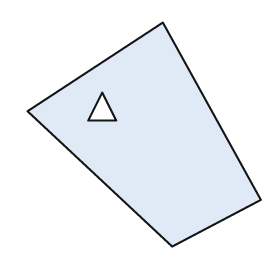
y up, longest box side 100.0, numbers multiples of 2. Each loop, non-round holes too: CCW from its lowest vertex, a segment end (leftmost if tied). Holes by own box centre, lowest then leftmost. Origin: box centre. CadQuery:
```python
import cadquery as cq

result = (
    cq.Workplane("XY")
    .moveTo(12.0, -48.0)
    .lineTo(50.0, -28.0)
    .lineTo(8.0, 48.0)
    .lineTo(-50.0, 10.0)
    .close()
    .moveTo(-24.0, 6.0)
    .lineTo(-12.0, 6.0)
    .lineTo(-18.0, 18.0)
    .close()
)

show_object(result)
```